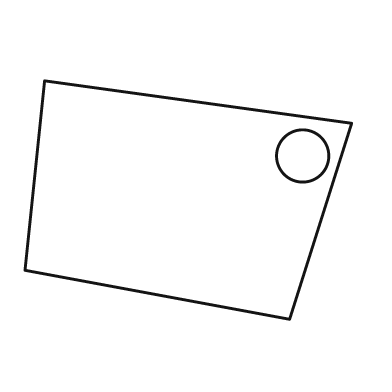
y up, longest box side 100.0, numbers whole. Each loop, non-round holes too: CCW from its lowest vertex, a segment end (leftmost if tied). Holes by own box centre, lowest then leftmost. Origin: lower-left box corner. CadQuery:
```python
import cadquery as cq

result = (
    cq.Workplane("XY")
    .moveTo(81.0, 0.0)
    .lineTo(100.0, 60.0)
    .lineTo(6.0, 73.0)
    .lineTo(0.0, 15.0)
    .close()
    .moveTo(85.0, 50.0)
    .circle(8.0)
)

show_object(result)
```